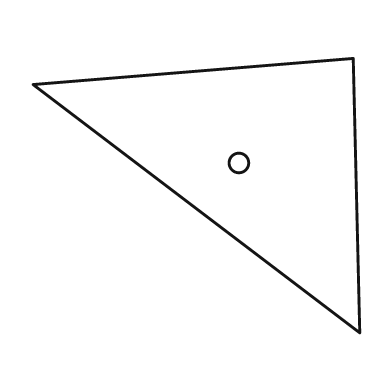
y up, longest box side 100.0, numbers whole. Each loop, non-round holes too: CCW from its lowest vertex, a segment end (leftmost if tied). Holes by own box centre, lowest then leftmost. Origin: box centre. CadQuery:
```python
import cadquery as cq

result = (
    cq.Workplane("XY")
    .moveTo(50.0, -42.0)
    .lineTo(48.0, 42.0)
    .lineTo(-50.0, 34.0)
    .close()
    .moveTo(13.0, 10.0)
    .circle(3.0)
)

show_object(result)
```